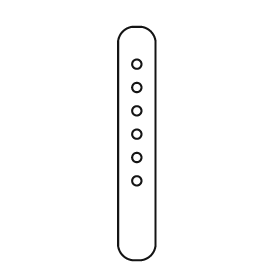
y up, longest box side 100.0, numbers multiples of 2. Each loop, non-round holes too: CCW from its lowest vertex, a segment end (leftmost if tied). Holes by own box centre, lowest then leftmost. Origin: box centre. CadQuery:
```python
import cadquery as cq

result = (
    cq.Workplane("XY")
    .moveTo(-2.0, -50.0)
    .lineTo(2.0, -50.0)
    .threePointArc((6.0, -48.0), (8.0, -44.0))
    .lineTo(8.0, 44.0)
    .threePointArc((6.0, 48.0), (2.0, 50.0))
    .lineTo(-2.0, 50.0)
    .threePointArc((-6.0, 48.0), (-8.0, 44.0))
    .lineTo(-8.0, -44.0)
    .threePointArc((-6.0, -48.0), (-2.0, -50.0))
    .close()
    .moveTo(0.0, -16.0)
    .circle(2.0)
    .moveTo(0.0, -6.0)
    .circle(2.0)
    .moveTo(0.0, 4.0)
    .circle(2.0)
    .moveTo(0.0, 14.0)
    .circle(2.0)
    .moveTo(0.0, 24.0)
    .circle(2.0)
    .moveTo(0.0, 34.0)
    .circle(2.0)
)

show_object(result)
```